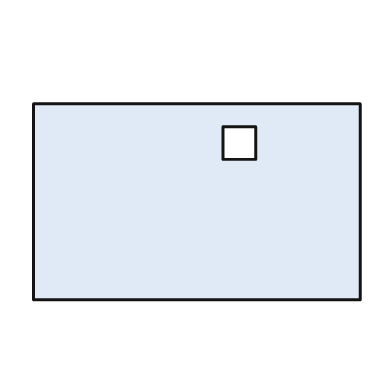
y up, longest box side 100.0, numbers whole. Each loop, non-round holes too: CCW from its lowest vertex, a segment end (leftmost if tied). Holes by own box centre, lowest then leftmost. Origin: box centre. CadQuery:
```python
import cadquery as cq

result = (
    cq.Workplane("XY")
    .moveTo(-50.0, -30.0)
    .lineTo(50.0, -30.0)
    .lineTo(50.0, 30.0)
    .lineTo(-50.0, 30.0)
    .close()
    .moveTo(8.0, 13.0)
    .lineTo(18.0, 13.0)
    .lineTo(18.0, 23.0)
    .lineTo(8.0, 23.0)
    .close()
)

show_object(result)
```